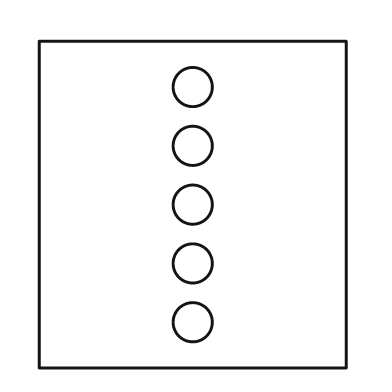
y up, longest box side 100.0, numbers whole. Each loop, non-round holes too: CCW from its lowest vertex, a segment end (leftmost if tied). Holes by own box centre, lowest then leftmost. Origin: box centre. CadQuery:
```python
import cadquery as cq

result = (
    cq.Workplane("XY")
    .moveTo(-47.0, -50.0)
    .lineTo(47.0, -50.0)
    .lineTo(47.0, 50.0)
    .lineTo(-47.0, 50.0)
    .close()
    .moveTo(0.0, -36.0)
    .circle(6.0)
    .moveTo(0.0, -18.0)
    .circle(6.0)
    .moveTo(0.0, 0.0)
    .circle(6.0)
    .moveTo(0.0, 18.0)
    .circle(6.0)
    .moveTo(0.0, 36.0)
    .circle(6.0)
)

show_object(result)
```